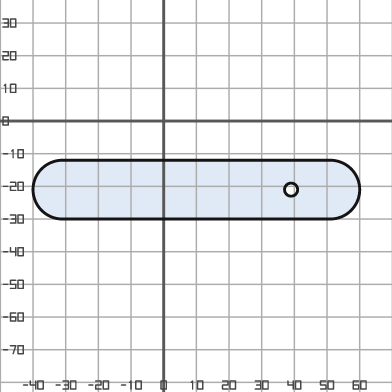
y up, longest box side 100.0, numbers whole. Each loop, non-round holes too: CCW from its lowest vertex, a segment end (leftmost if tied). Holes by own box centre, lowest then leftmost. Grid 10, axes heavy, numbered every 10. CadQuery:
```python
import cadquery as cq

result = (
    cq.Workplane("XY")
    .moveTo(-31.0, -30.0)
    .lineTo(51.0, -30.0)
    .threePointArc((60.0, -21.0), (51.0, -12.0))
    .lineTo(-31.0, -12.0)
    .threePointArc((-40.0, -21.0), (-31.0, -30.0))
    .close()
    .moveTo(39.0, -21.0)
    .circle(2.0)
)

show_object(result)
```